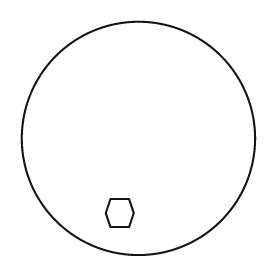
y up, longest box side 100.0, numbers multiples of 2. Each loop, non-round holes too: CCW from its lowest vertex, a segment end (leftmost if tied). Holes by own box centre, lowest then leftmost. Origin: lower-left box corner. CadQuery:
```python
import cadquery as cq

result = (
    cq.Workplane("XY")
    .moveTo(50.0, 50.0)
    .circle(50.0)
    .moveTo(38.0, 12.0)
    .lineTo(46.0, 12.0)
    .lineTo(48.0, 18.0)
    .lineTo(46.0, 24.0)
    .lineTo(38.0, 24.0)
    .lineTo(36.0, 18.0)
    .close()
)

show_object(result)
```